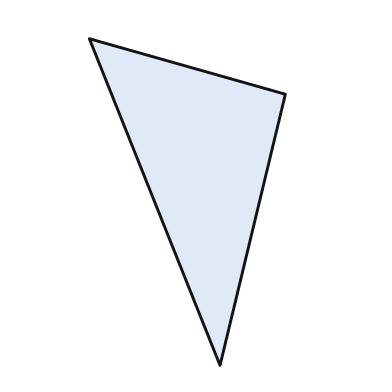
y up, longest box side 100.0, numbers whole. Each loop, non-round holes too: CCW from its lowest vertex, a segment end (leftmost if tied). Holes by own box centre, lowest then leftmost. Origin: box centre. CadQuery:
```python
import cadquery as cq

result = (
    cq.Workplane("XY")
    .moveTo(10.0, -50.0)
    .lineTo(30.0, 33.0)
    .lineTo(-30.0, 50.0)
    .close()
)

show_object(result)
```